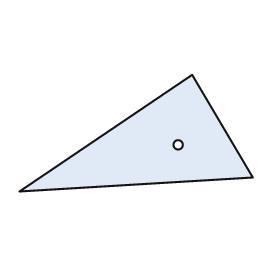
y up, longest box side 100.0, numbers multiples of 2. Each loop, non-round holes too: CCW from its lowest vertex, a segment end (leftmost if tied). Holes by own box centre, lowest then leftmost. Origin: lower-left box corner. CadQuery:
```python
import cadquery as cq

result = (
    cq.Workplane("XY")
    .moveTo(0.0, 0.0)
    .lineTo(100.0, 6.0)
    .lineTo(74.0, 50.0)
    .close()
    .moveTo(68.0, 20.0)
    .circle(2.0)
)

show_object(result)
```